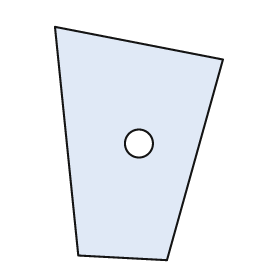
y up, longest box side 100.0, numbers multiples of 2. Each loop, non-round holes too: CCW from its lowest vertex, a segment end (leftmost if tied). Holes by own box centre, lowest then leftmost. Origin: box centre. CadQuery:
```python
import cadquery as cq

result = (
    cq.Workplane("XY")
    .moveTo(12.0, -50.0)
    .lineTo(36.0, 36.0)
    .lineTo(-36.0, 50.0)
    .lineTo(-26.0, -48.0)
    .close()
    .moveTo(0.0, 0.0)
    .circle(6.0)
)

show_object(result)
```